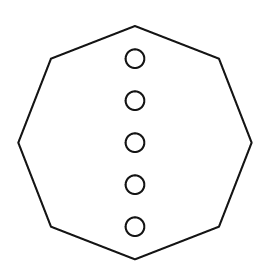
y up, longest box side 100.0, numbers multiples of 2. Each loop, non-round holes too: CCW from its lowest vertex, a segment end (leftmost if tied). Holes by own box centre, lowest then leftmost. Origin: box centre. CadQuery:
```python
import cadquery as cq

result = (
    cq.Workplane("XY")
    .moveTo(0.0, -50.0)
    .lineTo(36.0, -36.0)
    .lineTo(50.0, 0.0)
    .lineTo(36.0, 36.0)
    .lineTo(0.0, 50.0)
    .lineTo(-36.0, 36.0)
    .lineTo(-50.0, 0.0)
    .lineTo(-36.0, -36.0)
    .close()
    .moveTo(0.0, -36.0)
    .circle(4.0)
    .moveTo(0.0, -18.0)
    .circle(4.0)
    .moveTo(0.0, 0.0)
    .circle(4.0)
    .moveTo(0.0, 18.0)
    .circle(4.0)
    .moveTo(0.0, 36.0)
    .circle(4.0)
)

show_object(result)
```